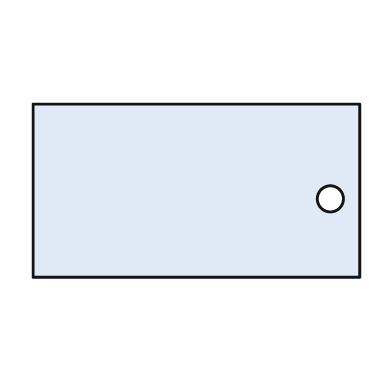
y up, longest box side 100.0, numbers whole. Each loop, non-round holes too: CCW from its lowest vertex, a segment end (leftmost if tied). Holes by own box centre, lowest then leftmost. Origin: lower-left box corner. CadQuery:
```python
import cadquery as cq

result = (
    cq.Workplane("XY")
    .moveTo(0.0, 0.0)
    .lineTo(100.0, 0.0)
    .lineTo(100.0, 53.0)
    .lineTo(0.0, 53.0)
    .close()
    .moveTo(91.0, 24.0)
    .circle(4.0)
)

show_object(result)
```